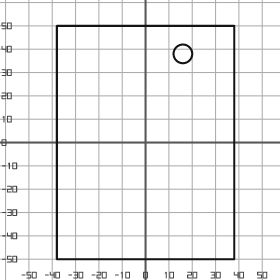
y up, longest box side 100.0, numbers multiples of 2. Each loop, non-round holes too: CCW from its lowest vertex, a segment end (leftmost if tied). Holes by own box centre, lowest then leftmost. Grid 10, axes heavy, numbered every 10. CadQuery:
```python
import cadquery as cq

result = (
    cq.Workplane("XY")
    .moveTo(-38.0, -50.0)
    .lineTo(38.0, -50.0)
    .lineTo(38.0, 50.0)
    .lineTo(-38.0, 50.0)
    .close()
    .moveTo(16.0, 38.0)
    .circle(4.0)
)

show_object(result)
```